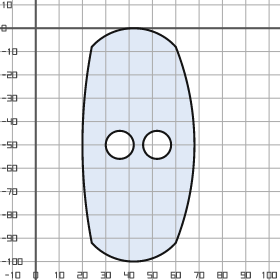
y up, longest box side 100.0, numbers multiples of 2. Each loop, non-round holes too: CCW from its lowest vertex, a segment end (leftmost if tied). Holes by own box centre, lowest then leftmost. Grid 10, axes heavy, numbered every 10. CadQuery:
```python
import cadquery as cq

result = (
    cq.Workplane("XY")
    .moveTo(24.0, -92.0)
    .threePointArc((42.0, -100.0), (60.0, -92.0))
    .threePointArc((68.0, -50.0), (60.0, -8.0))
    .threePointArc((42.0, 0.0), (24.0, -8.0))
    .threePointArc((20.0, -50.0), (24.0, -92.0))
    .close()
    .moveTo(36.0, -50.0)
    .circle(6.0)
    .moveTo(52.0, -50.0)
    .circle(6.0)
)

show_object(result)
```